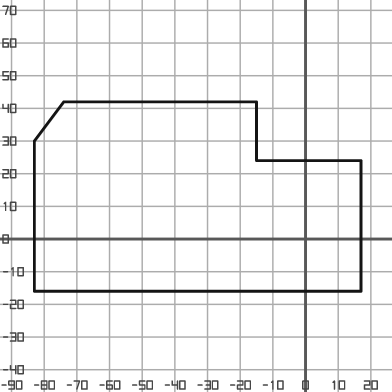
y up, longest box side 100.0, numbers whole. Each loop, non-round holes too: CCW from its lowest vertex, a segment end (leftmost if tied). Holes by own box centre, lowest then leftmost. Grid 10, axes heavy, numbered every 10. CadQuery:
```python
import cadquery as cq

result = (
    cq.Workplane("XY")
    .moveTo(-83.0, -16.0)
    .lineTo(17.0, -16.0)
    .lineTo(17.0, 24.0)
    .lineTo(-15.0, 24.0)
    .lineTo(-15.0, 42.0)
    .lineTo(-74.0, 42.0)
    .lineTo(-83.0, 30.0)
    .close()
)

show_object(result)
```